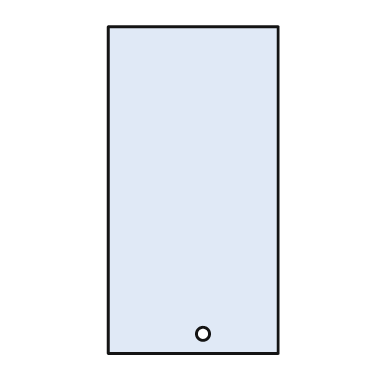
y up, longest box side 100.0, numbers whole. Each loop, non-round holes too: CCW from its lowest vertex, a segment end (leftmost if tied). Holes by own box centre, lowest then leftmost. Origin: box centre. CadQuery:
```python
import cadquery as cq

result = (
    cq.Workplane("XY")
    .moveTo(-26.0, -50.0)
    .lineTo(26.0, -50.0)
    .lineTo(26.0, 50.0)
    .lineTo(-26.0, 50.0)
    .close()
    .moveTo(3.0, -44.0)
    .circle(2.0)
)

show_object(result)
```